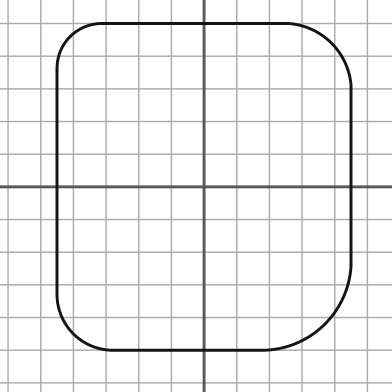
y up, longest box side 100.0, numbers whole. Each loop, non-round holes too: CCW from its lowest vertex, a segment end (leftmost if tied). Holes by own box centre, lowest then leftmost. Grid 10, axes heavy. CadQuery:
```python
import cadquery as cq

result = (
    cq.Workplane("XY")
    .moveTo(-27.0, -50.0)
    .lineTo(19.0, -50.0)
    .threePointArc((37.0, -42.0), (45.0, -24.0))
    .lineTo(45.0, 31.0)
    .threePointArc((39.0, 44.0), (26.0, 50.0))
    .lineTo(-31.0, 50.0)
    .threePointArc((-41.0, 46.0), (-45.0, 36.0))
    .lineTo(-45.0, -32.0)
    .threePointArc((-40.0, -45.0), (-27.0, -50.0))
    .close()
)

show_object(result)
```